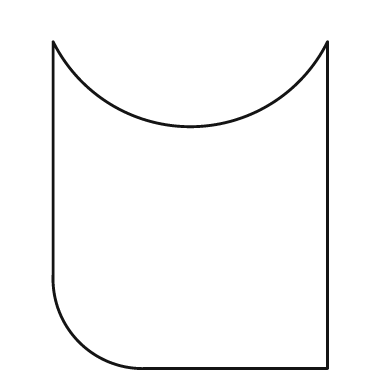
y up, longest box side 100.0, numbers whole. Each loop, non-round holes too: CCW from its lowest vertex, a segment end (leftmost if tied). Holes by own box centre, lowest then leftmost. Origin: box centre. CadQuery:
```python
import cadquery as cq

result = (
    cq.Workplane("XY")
    .moveTo(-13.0, -50.0)
    .lineTo(42.0, -50.0)
    .lineTo(42.0, 50.0)
    .threePointArc((0.0, 24.0), (-42.0, 50.0))
    .lineTo(-42.0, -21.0)
    .threePointArc((-34.0, -42.0), (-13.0, -50.0))
    .close()
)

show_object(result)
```